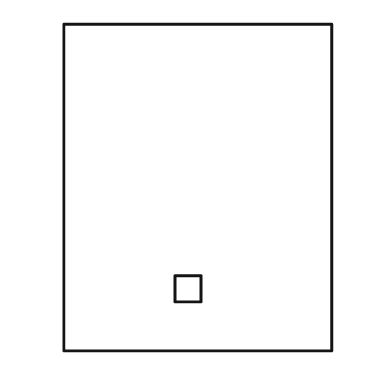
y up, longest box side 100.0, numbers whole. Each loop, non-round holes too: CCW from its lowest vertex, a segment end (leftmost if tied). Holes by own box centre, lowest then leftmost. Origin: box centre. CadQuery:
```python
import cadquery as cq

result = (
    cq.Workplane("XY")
    .moveTo(-41.0, -50.0)
    .lineTo(41.0, -50.0)
    .lineTo(41.0, 50.0)
    .lineTo(-41.0, 50.0)
    .close()
    .moveTo(-7.0, -35.0)
    .lineTo(1.0, -35.0)
    .lineTo(1.0, -27.0)
    .lineTo(-7.0, -27.0)
    .close()
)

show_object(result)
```